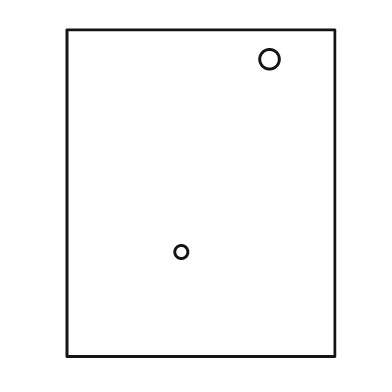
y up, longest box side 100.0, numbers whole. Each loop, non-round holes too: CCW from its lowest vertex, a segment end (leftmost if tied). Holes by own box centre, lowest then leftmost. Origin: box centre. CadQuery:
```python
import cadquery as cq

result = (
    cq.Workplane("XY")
    .moveTo(-41.0, -50.0)
    .lineTo(41.0, -50.0)
    .lineTo(41.0, 50.0)
    .lineTo(-41.0, 50.0)
    .close()
    .moveTo(-6.0, -18.0)
    .circle(2.0)
    .moveTo(21.0, 41.0)
    .circle(3.0)
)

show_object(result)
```